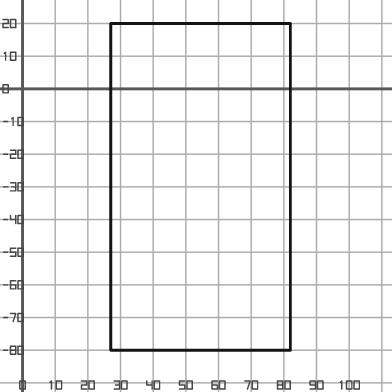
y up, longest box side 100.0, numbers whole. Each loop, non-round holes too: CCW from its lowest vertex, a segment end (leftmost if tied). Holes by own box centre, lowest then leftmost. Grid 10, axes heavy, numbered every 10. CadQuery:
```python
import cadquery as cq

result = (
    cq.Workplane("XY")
    .moveTo(27.0, -80.0)
    .lineTo(82.0, -80.0)
    .lineTo(82.0, 20.0)
    .lineTo(27.0, 20.0)
    .close()
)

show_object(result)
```